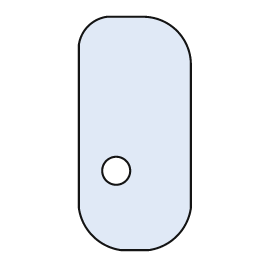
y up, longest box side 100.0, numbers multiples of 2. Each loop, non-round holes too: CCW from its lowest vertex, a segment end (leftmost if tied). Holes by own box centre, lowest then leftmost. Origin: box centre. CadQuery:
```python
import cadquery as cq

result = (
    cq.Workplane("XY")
    .moveTo(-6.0, -50.0)
    .lineTo(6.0, -50.0)
    .threePointArc((18.0, -44.0), (24.0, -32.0))
    .lineTo(24.0, 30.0)
    .threePointArc((18.0, 44.0), (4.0, 50.0))
    .lineTo(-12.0, 50.0)
    .threePointArc((-20.0, 46.0), (-24.0, 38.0))
    .lineTo(-24.0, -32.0)
    .threePointArc((-18.0, -44.0), (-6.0, -50.0))
    .close()
    .moveTo(-8.0, -16.0)
    .circle(6.0)
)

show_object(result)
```